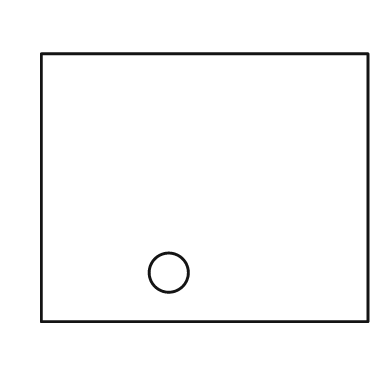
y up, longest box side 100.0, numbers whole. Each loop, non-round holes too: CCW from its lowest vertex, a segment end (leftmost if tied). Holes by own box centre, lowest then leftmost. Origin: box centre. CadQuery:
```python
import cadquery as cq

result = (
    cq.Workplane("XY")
    .moveTo(-50.0, -41.0)
    .lineTo(50.0, -41.0)
    .lineTo(50.0, 41.0)
    .lineTo(-50.0, 41.0)
    .close()
    .moveTo(-11.0, -26.0)
    .circle(6.0)
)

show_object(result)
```